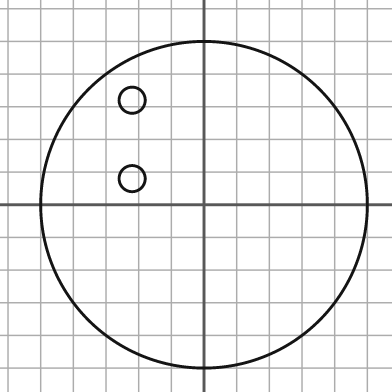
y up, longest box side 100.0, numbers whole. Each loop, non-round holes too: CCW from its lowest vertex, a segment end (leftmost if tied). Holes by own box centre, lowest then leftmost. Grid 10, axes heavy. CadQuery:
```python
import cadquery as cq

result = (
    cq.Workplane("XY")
    .moveTo(0.0, 0.0)
    .circle(50.0)
    .moveTo(-22.0, 8.0)
    .circle(4.0)
    .moveTo(-22.0, 32.0)
    .circle(4.0)
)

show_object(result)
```